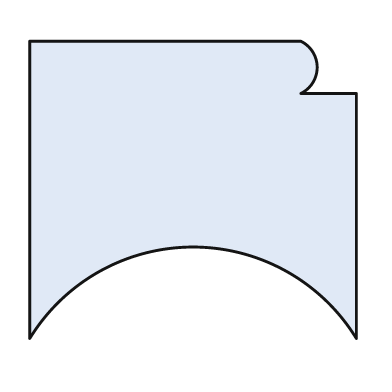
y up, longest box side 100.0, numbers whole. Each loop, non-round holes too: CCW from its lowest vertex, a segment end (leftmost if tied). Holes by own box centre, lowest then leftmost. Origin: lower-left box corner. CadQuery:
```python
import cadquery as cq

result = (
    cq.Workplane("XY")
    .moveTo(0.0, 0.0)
    .threePointArc((50.0, 28.0), (100.0, 0.0))
    .lineTo(100.0, 75.0)
    .lineTo(83.0, 75.0)
    .threePointArc((88.0, 83.0), (83.0, 91.0))
    .lineTo(0.0, 91.0)
    .close()
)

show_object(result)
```